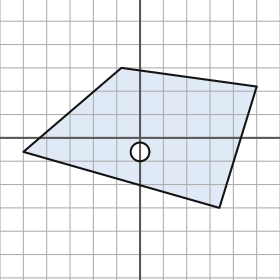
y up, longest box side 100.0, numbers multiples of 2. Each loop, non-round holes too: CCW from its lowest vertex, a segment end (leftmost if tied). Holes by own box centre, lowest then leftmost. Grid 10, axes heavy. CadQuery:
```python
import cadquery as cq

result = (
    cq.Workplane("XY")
    .moveTo(34.0, -30.0)
    .lineTo(50.0, 22.0)
    .lineTo(-8.0, 30.0)
    .lineTo(-50.0, -6.0)
    .close()
    .moveTo(0.0, -6.0)
    .circle(4.0)
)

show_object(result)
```